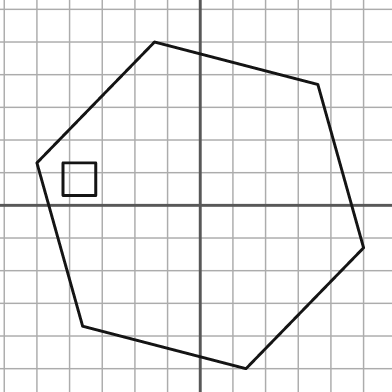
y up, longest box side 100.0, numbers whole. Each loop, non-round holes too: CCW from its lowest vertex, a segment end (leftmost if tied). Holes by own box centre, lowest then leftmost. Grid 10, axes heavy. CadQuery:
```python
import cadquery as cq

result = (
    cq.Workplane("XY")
    .moveTo(14.0, -50.0)
    .lineTo(50.0, -13.0)
    .lineTo(36.0, 37.0)
    .lineTo(-14.0, 50.0)
    .lineTo(-50.0, 13.0)
    .lineTo(-36.0, -37.0)
    .close()
    .moveTo(-42.0, 3.0)
    .lineTo(-32.0, 3.0)
    .lineTo(-32.0, 13.0)
    .lineTo(-42.0, 13.0)
    .close()
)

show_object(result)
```